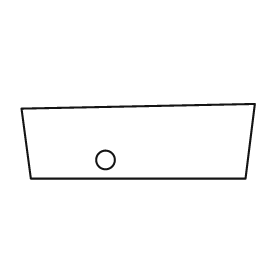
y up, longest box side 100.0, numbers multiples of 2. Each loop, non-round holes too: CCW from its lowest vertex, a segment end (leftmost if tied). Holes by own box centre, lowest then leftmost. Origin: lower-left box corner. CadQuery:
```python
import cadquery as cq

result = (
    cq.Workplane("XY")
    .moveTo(4.0, 0.0)
    .lineTo(96.0, 0.0)
    .lineTo(100.0, 32.0)
    .lineTo(0.0, 30.0)
    .close()
    .moveTo(36.0, 8.0)
    .circle(4.0)
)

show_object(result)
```